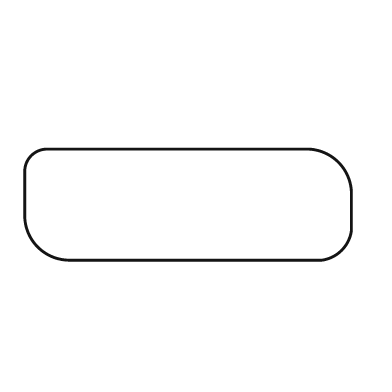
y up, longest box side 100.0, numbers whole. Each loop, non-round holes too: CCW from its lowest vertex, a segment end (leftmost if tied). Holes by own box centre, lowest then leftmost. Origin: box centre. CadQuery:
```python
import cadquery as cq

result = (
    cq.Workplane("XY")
    .moveTo(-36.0, -17.0)
    .lineTo(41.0, -17.0)
    .threePointArc((47.0, -14.0), (50.0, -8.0))
    .lineTo(50.0, 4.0)
    .threePointArc((46.0, 13.0), (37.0, 17.0))
    .lineTo(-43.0, 17.0)
    .threePointArc((-48.0, 15.0), (-50.0, 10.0))
    .lineTo(-50.0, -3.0)
    .threePointArc((-46.0, -13.0), (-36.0, -17.0))
    .close()
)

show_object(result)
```